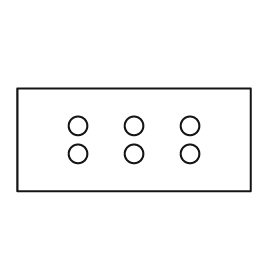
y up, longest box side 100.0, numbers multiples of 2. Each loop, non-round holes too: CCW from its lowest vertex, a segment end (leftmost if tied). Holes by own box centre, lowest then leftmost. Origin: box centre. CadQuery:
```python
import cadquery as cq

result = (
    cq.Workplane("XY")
    .moveTo(-50.0, -22.0)
    .lineTo(50.0, -22.0)
    .lineTo(50.0, 22.0)
    .lineTo(-50.0, 22.0)
    .close()
    .moveTo(-24.0, -6.0)
    .circle(4.0)
    .moveTo(0.0, -6.0)
    .circle(4.0)
    .moveTo(24.0, -6.0)
    .circle(4.0)
    .moveTo(-24.0, 6.0)
    .circle(4.0)
    .moveTo(0.0, 6.0)
    .circle(4.0)
    .moveTo(24.0, 6.0)
    .circle(4.0)
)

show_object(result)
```